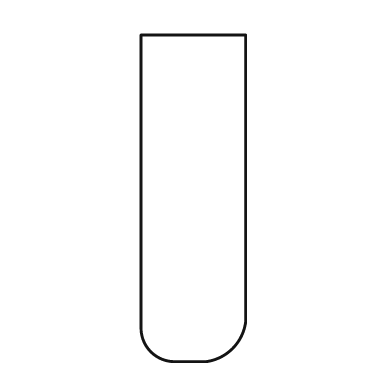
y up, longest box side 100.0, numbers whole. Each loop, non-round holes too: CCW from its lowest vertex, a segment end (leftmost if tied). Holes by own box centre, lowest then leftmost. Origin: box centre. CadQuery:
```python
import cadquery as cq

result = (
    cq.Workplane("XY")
    .moveTo(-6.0, -50.0)
    .lineTo(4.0, -50.0)
    .threePointArc((12.0, -46.0), (16.0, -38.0))
    .lineTo(16.0, 50.0)
    .lineTo(-16.0, 50.0)
    .lineTo(-16.0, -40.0)
    .threePointArc((-13.0, -47.0), (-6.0, -50.0))
    .close()
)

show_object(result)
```